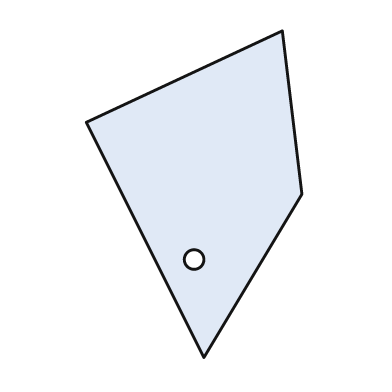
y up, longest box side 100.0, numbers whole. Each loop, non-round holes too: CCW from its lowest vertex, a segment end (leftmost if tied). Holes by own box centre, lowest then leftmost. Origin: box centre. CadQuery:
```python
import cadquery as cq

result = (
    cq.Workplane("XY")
    .moveTo(3.0, -50.0)
    .lineTo(33.0, 0.0)
    .lineTo(27.0, 50.0)
    .lineTo(-33.0, 22.0)
    .close()
    .moveTo(0.0, -20.0)
    .circle(3.0)
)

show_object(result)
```